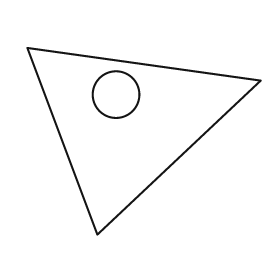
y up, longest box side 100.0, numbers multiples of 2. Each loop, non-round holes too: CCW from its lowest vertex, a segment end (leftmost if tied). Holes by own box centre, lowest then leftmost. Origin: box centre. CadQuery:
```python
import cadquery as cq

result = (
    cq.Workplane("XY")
    .moveTo(-20.0, -40.0)
    .lineTo(50.0, 26.0)
    .lineTo(-50.0, 40.0)
    .close()
    .moveTo(-12.0, 20.0)
    .circle(10.0)
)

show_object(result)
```